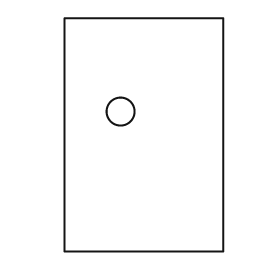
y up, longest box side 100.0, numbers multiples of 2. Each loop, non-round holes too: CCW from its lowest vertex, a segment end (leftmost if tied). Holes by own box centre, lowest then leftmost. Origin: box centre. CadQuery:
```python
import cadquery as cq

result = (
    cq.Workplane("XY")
    .moveTo(-34.0, -50.0)
    .lineTo(34.0, -50.0)
    .lineTo(34.0, 50.0)
    .lineTo(-34.0, 50.0)
    .close()
    .moveTo(-10.0, 10.0)
    .circle(6.0)
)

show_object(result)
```